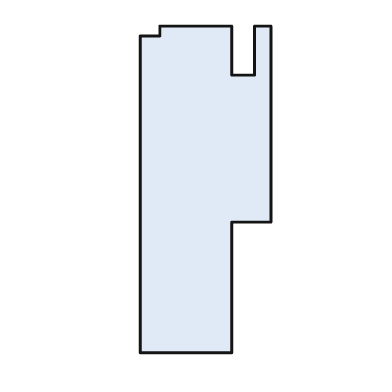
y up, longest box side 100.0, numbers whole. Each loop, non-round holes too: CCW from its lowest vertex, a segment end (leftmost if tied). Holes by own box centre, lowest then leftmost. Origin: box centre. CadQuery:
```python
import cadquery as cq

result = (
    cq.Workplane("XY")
    .moveTo(-20.0, -50.0)
    .lineTo(8.0, -50.0)
    .lineTo(8.0, -10.0)
    .lineTo(20.0, -10.0)
    .lineTo(20.0, 50.0)
    .lineTo(15.0, 50.0)
    .lineTo(15.0, 35.0)
    .lineTo(8.0, 35.0)
    .lineTo(8.0, 50.0)
    .lineTo(-14.0, 50.0)
    .lineTo(-14.0, 47.0)
    .lineTo(-20.0, 47.0)
    .close()
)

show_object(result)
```